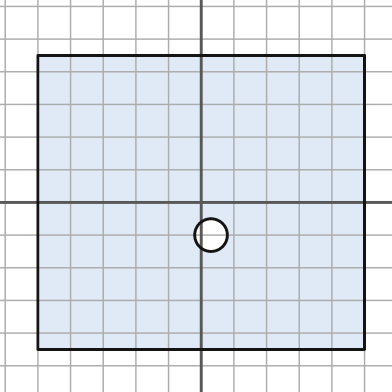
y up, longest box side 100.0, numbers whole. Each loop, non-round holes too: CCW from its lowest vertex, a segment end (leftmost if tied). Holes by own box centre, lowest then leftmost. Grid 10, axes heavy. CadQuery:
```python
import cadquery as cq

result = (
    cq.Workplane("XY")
    .moveTo(-50.0, -45.0)
    .lineTo(50.0, -45.0)
    .lineTo(50.0, 45.0)
    .lineTo(-50.0, 45.0)
    .close()
    .moveTo(3.0, -10.0)
    .circle(5.0)
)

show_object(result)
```